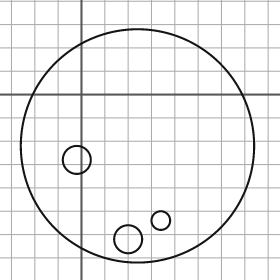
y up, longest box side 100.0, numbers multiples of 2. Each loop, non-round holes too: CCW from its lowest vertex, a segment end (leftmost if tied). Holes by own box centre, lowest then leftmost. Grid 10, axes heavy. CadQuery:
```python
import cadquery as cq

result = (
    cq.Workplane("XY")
    .moveTo(24.0, -22.0)
    .circle(50.0)
    .moveTo(20.0, -62.0)
    .circle(6.0)
    .moveTo(34.0, -54.0)
    .circle(4.0)
    .moveTo(-2.0, -28.0)
    .circle(6.0)
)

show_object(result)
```